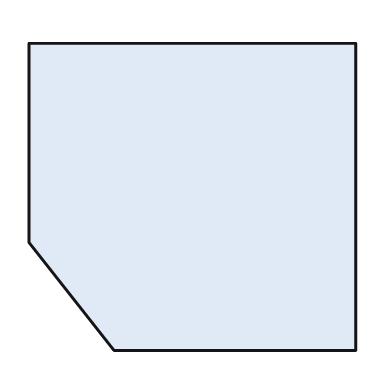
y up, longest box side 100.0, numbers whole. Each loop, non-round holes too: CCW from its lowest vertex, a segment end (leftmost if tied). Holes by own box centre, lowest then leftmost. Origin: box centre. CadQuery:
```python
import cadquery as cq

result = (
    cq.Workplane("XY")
    .moveTo(-24.0, -47.0)
    .lineTo(50.0, -47.0)
    .lineTo(50.0, 47.0)
    .lineTo(-50.0, 47.0)
    .lineTo(-50.0, -14.0)
    .close()
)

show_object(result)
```